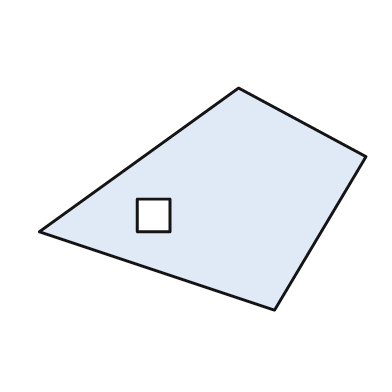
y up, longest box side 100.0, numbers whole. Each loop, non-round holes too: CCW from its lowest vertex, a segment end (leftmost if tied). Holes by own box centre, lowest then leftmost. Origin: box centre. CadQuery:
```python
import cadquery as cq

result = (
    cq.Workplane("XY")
    .moveTo(22.0, -34.0)
    .lineTo(50.0, 13.0)
    .lineTo(11.0, 34.0)
    .lineTo(-50.0, -10.0)
    .close()
    .moveTo(-20.0, -10.0)
    .lineTo(-10.0, -10.0)
    .lineTo(-10.0, 0.0)
    .lineTo(-20.0, 0.0)
    .close()
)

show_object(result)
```